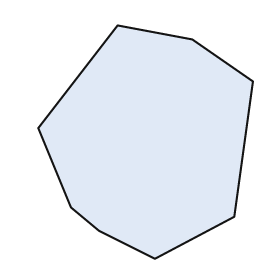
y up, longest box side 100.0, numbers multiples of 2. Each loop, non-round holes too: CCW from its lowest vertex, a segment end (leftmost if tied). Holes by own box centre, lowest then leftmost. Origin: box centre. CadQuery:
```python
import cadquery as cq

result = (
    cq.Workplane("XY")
    .moveTo(4.0, -50.0)
    .lineTo(38.0, -32.0)
    .lineTo(46.0, 26.0)
    .lineTo(20.0, 44.0)
    .lineTo(-12.0, 50.0)
    .lineTo(-46.0, 6.0)
    .lineTo(-32.0, -28.0)
    .lineTo(-20.0, -38.0)
    .close()
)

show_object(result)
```